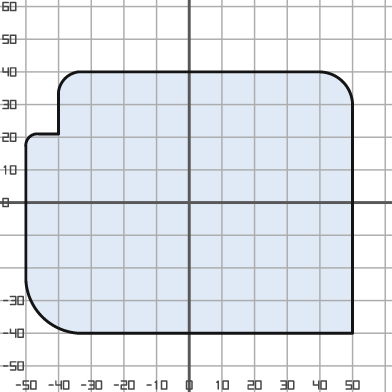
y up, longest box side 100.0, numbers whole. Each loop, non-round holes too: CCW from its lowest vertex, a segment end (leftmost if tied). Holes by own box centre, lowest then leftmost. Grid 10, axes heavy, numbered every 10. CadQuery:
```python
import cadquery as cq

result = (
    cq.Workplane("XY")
    .moveTo(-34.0, -40.0)
    .lineTo(50.0, -40.0)
    .lineTo(50.0, 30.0)
    .threePointArc((47.0, 37.0), (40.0, 40.0))
    .lineTo(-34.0, 40.0)
    .threePointArc((-38.0, 38.0), (-40.0, 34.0))
    .lineTo(-40.0, 21.0)
    .lineTo(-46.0, 21.0)
    .threePointArc((-49.0, 20.0), (-50.0, 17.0))
    .lineTo(-50.0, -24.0)
    .threePointArc((-45.0, -35.0), (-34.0, -40.0))
    .close()
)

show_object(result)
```